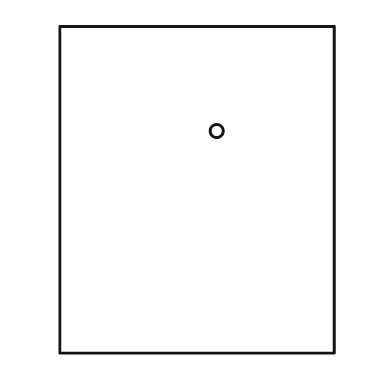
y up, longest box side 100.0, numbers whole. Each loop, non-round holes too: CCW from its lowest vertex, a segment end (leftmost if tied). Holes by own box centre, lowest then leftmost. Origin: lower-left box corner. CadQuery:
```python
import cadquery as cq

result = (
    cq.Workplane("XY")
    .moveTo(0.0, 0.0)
    .lineTo(84.0, 0.0)
    .lineTo(84.0, 100.0)
    .lineTo(0.0, 100.0)
    .close()
    .moveTo(48.0, 68.0)
    .circle(2.0)
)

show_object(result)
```